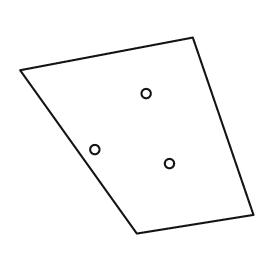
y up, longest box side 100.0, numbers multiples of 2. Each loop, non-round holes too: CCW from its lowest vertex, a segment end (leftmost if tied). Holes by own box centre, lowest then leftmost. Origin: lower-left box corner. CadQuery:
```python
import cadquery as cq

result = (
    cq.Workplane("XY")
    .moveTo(50.0, 0.0)
    .lineTo(100.0, 8.0)
    .lineTo(74.0, 84.0)
    .lineTo(0.0, 70.0)
    .close()
    .moveTo(64.0, 30.0)
    .circle(2.0)
    .moveTo(32.0, 36.0)
    .circle(2.0)
    .moveTo(54.0, 60.0)
    .circle(2.0)
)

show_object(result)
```